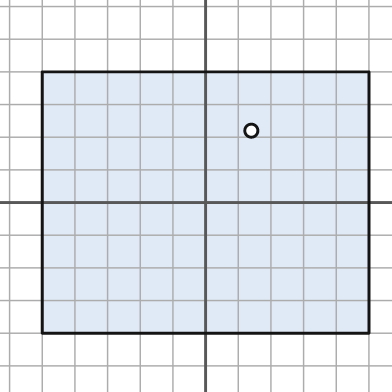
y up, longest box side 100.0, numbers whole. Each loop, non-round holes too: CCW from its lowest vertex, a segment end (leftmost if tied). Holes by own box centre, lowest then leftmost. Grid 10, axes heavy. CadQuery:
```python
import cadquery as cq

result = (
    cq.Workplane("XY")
    .moveTo(-50.0, -40.0)
    .lineTo(50.0, -40.0)
    .lineTo(50.0, 40.0)
    .lineTo(-50.0, 40.0)
    .close()
    .moveTo(14.0, 22.0)
    .circle(2.0)
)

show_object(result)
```